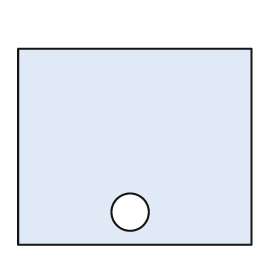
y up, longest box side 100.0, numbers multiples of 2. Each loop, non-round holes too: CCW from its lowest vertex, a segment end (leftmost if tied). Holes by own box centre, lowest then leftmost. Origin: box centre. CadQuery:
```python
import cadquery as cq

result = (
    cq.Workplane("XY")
    .moveTo(-50.0, -42.0)
    .lineTo(50.0, -42.0)
    .lineTo(50.0, 42.0)
    .lineTo(-50.0, 42.0)
    .close()
    .moveTo(-2.0, -28.0)
    .circle(8.0)
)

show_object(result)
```